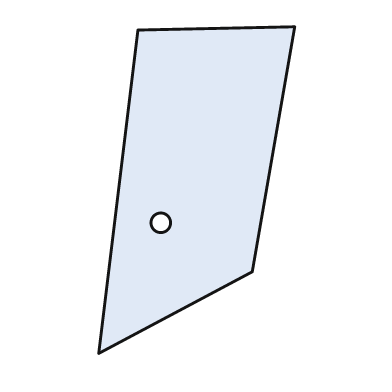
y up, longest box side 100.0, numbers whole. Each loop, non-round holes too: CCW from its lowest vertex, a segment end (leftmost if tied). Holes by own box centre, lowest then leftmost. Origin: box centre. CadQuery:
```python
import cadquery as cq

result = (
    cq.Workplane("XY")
    .moveTo(-30.0, -50.0)
    .lineTo(17.0, -25.0)
    .lineTo(30.0, 50.0)
    .lineTo(-18.0, 49.0)
    .close()
    .moveTo(-11.0, -10.0)
    .circle(3.0)
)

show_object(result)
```